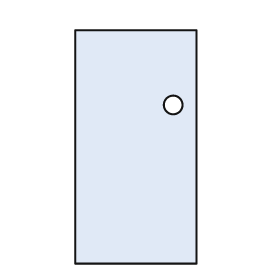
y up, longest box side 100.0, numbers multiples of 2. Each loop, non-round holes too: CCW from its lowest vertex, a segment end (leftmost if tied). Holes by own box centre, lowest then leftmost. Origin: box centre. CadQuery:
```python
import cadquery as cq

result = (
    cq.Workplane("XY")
    .moveTo(-26.0, -50.0)
    .lineTo(26.0, -50.0)
    .lineTo(26.0, 50.0)
    .lineTo(-26.0, 50.0)
    .close()
    .moveTo(16.0, 18.0)
    .circle(4.0)
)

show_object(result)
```